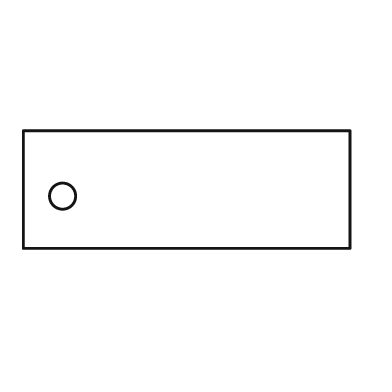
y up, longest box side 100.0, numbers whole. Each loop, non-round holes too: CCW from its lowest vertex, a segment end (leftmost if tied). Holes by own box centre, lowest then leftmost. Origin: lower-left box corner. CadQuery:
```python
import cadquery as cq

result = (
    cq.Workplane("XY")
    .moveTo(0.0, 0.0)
    .lineTo(100.0, 0.0)
    .lineTo(100.0, 36.0)
    .lineTo(0.0, 36.0)
    .close()
    .moveTo(12.0, 16.0)
    .circle(4.0)
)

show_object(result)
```